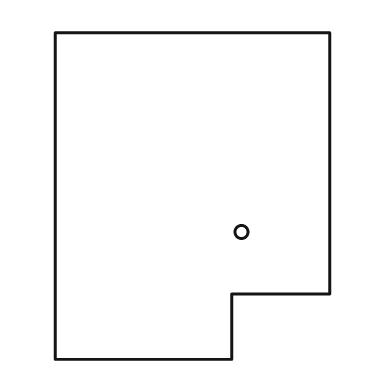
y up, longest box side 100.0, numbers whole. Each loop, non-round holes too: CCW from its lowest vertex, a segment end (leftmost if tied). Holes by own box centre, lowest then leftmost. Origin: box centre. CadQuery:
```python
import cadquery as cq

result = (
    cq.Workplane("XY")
    .moveTo(-42.0, -50.0)
    .lineTo(12.0, -50.0)
    .lineTo(12.0, -30.0)
    .lineTo(42.0, -30.0)
    .lineTo(42.0, 50.0)
    .lineTo(-42.0, 50.0)
    .close()
    .moveTo(15.0, -11.0)
    .circle(2.0)
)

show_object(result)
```